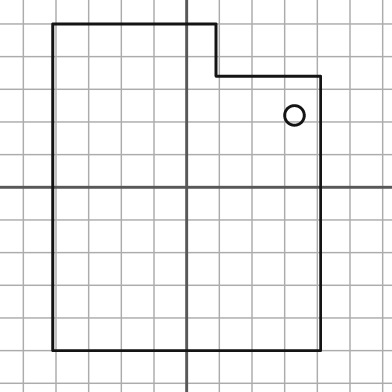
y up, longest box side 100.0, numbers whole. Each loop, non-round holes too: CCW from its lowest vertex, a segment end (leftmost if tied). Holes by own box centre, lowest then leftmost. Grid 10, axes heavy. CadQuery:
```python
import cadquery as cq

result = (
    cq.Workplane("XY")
    .moveTo(-41.0, -50.0)
    .lineTo(41.0, -50.0)
    .lineTo(41.0, 34.0)
    .lineTo(9.0, 34.0)
    .lineTo(9.0, 50.0)
    .lineTo(-41.0, 50.0)
    .close()
    .moveTo(33.0, 22.0)
    .circle(3.0)
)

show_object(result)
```